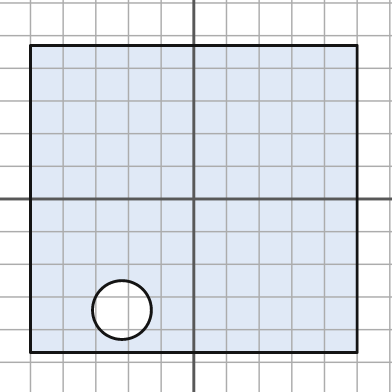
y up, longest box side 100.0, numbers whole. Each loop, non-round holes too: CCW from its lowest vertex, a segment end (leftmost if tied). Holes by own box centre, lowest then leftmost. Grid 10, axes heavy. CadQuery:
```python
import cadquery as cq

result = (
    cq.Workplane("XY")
    .moveTo(-50.0, -47.0)
    .lineTo(50.0, -47.0)
    .lineTo(50.0, 47.0)
    .lineTo(-50.0, 47.0)
    .close()
    .moveTo(-22.0, -34.0)
    .circle(9.0)
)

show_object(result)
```